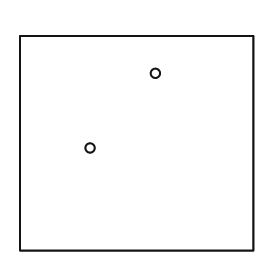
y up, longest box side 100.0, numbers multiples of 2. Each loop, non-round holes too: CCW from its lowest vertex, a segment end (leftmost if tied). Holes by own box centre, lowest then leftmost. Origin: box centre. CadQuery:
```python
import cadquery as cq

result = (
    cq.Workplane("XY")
    .moveTo(-50.0, -46.0)
    .lineTo(50.0, -46.0)
    .lineTo(50.0, 46.0)
    .lineTo(-50.0, 46.0)
    .close()
    .moveTo(-20.0, -2.0)
    .circle(2.0)
    .moveTo(8.0, 30.0)
    .circle(2.0)
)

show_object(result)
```